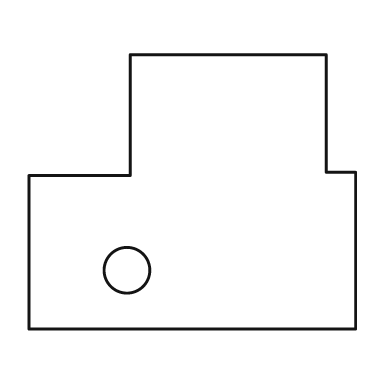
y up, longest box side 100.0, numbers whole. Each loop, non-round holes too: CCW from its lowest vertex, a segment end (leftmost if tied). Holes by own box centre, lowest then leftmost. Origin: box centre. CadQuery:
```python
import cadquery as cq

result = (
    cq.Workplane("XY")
    .moveTo(-50.0, -42.0)
    .lineTo(50.0, -42.0)
    .lineTo(50.0, 6.0)
    .lineTo(41.0, 6.0)
    .lineTo(41.0, 42.0)
    .lineTo(-19.0, 42.0)
    .lineTo(-19.0, 5.0)
    .lineTo(-50.0, 5.0)
    .close()
    .moveTo(-20.0, -24.0)
    .circle(7.0)
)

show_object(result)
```